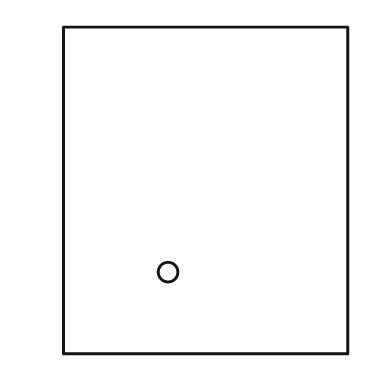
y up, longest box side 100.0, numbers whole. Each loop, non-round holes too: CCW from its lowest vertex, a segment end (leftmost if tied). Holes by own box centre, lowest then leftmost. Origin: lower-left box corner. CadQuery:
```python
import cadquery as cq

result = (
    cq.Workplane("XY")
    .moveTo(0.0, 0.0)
    .lineTo(87.0, 0.0)
    .lineTo(87.0, 100.0)
    .lineTo(0.0, 100.0)
    .close()
    .moveTo(32.0, 25.0)
    .circle(3.0)
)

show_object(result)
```